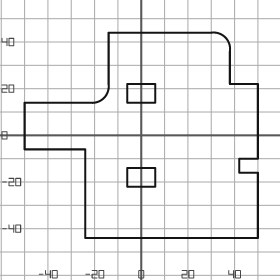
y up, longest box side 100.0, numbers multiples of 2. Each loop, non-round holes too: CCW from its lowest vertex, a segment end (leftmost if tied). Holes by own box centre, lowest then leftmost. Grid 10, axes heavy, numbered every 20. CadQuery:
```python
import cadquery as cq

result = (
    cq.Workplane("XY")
    .moveTo(-24.0, -44.0)
    .lineTo(50.0, -44.0)
    .lineTo(50.0, -16.0)
    .lineTo(42.0, -16.0)
    .lineTo(42.0, -10.0)
    .lineTo(50.0, -10.0)
    .lineTo(50.0, 22.0)
    .lineTo(38.0, 22.0)
    .lineTo(38.0, 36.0)
    .threePointArc((36.0, 42.0), (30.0, 44.0))
    .lineTo(-14.0, 44.0)
    .lineTo(-14.0, 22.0)
    .threePointArc((-16.0, 16.0), (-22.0, 14.0))
    .lineTo(-50.0, 14.0)
    .lineTo(-50.0, -6.0)
    .lineTo(-24.0, -6.0)
    .close()
    .moveTo(-6.0, -22.0)
    .lineTo(6.0, -22.0)
    .lineTo(6.0, -14.0)
    .lineTo(-6.0, -14.0)
    .close()
    .moveTo(-6.0, 14.0)
    .lineTo(6.0, 14.0)
    .lineTo(6.0, 22.0)
    .lineTo(-6.0, 22.0)
    .close()
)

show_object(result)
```